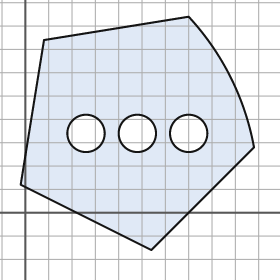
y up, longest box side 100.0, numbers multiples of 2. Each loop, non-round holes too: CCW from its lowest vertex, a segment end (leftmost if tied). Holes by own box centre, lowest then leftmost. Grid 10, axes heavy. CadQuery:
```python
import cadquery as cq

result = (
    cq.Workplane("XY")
    .moveTo(54.0, -16.0)
    .lineTo(98.0, 28.0)
    .threePointArc((88.0, 58.0), (70.0, 84.0))
    .lineTo(8.0, 74.0)
    .lineTo(-2.0, 12.0)
    .close()
    .moveTo(26.0, 34.0)
    .circle(8.0)
    .moveTo(48.0, 34.0)
    .circle(8.0)
    .moveTo(70.0, 34.0)
    .circle(8.0)
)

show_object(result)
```